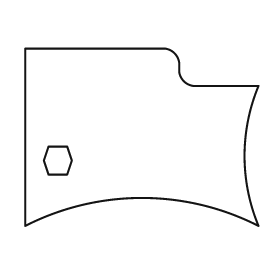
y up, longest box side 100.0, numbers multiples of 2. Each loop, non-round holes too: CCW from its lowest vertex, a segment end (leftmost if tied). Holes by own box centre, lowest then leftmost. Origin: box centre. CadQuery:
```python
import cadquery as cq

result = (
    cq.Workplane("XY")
    .moveTo(-50.0, -38.0)
    .threePointArc((0.0, -26.0), (50.0, -38.0))
    .threePointArc((44.0, -8.0), (50.0, 22.0))
    .lineTo(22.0, 22.0)
    .threePointArc((18.0, 24.0), (16.0, 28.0))
    .lineTo(16.0, 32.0)
    .threePointArc((14.0, 36.0), (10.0, 38.0))
    .lineTo(-50.0, 38.0)
    .close()
    .moveTo(-40.0, -16.0)
    .lineTo(-32.0, -16.0)
    .lineTo(-30.0, -10.0)
    .lineTo(-32.0, -4.0)
    .lineTo(-40.0, -4.0)
    .lineTo(-42.0, -10.0)
    .close()
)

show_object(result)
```